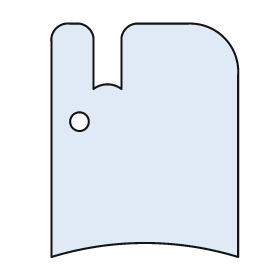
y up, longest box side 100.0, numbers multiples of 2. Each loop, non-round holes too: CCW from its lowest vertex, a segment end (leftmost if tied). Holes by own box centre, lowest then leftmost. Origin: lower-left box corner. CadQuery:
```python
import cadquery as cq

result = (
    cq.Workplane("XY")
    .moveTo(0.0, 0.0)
    .threePointArc((40.0, 6.0), (80.0, 0.0))
    .lineTo(80.0, 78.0)
    .threePointArc((74.0, 94.0), (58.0, 100.0))
    .lineTo(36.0, 100.0)
    .threePointArc((32.0, 98.0), (30.0, 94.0))
    .lineTo(30.0, 72.0)
    .threePointArc((24.0, 74.0), (18.0, 72.0))
    .lineTo(18.0, 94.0)
    .threePointArc((16.0, 98.0), (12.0, 100.0))
    .lineTo(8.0, 100.0)
    .threePointArc((2.0, 98.0), (0.0, 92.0))
    .close()
    .moveTo(12.0, 58.0)
    .circle(4.0)
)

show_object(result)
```